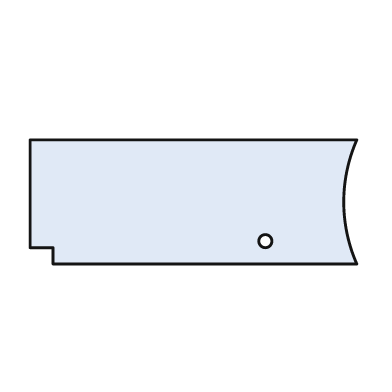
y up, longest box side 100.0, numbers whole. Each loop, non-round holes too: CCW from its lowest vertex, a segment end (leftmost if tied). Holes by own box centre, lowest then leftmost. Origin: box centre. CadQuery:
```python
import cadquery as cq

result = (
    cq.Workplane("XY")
    .moveTo(-43.0, -19.0)
    .lineTo(50.0, -19.0)
    .threePointArc((46.0, 0.0), (50.0, 19.0))
    .lineTo(-50.0, 19.0)
    .lineTo(-50.0, -14.0)
    .lineTo(-43.0, -14.0)
    .close()
    .moveTo(22.0, -12.0)
    .circle(2.0)
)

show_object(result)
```